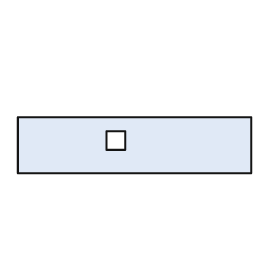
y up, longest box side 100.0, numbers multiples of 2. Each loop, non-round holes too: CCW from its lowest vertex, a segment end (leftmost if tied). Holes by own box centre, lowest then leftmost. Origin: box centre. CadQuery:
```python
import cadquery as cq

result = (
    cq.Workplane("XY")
    .moveTo(-50.0, -12.0)
    .lineTo(50.0, -12.0)
    .lineTo(50.0, 12.0)
    .lineTo(-50.0, 12.0)
    .close()
    .moveTo(-12.0, -2.0)
    .lineTo(-4.0, -2.0)
    .lineTo(-4.0, 6.0)
    .lineTo(-12.0, 6.0)
    .close()
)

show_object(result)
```